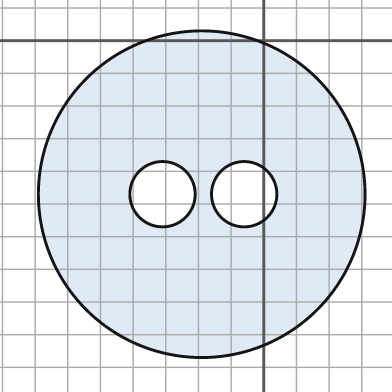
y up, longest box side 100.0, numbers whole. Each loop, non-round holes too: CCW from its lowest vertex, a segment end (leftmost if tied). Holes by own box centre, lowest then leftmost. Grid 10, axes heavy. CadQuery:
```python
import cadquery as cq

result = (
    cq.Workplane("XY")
    .moveTo(-19.0, -47.0)
    .circle(50.0)
    .moveTo(-31.0, -47.0)
    .circle(10.0)
    .moveTo(-6.0, -47.0)
    .circle(10.0)
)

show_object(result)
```